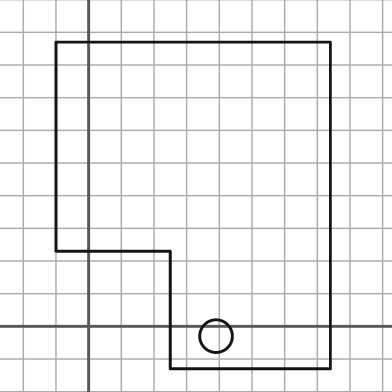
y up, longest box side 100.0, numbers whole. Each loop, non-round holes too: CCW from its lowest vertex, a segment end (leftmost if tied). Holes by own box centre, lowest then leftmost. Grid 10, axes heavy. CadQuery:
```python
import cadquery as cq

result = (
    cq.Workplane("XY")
    .moveTo(25.0, -13.0)
    .lineTo(74.0, -13.0)
    .lineTo(74.0, 87.0)
    .lineTo(-10.0, 87.0)
    .lineTo(-10.0, 23.0)
    .lineTo(25.0, 23.0)
    .close()
    .moveTo(39.0, -3.0)
    .circle(5.0)
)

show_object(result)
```